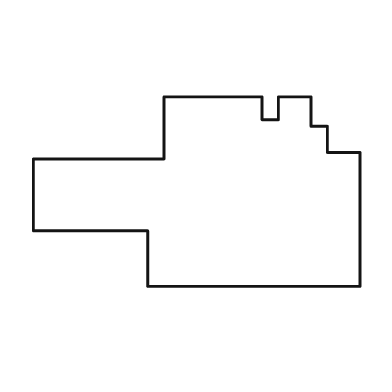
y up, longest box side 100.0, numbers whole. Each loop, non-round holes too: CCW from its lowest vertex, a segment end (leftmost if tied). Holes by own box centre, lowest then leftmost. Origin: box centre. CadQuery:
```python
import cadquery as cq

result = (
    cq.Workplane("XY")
    .moveTo(-15.0, -29.0)
    .lineTo(50.0, -29.0)
    .lineTo(50.0, 12.0)
    .lineTo(40.0, 12.0)
    .lineTo(40.0, 20.0)
    .lineTo(35.0, 20.0)
    .lineTo(35.0, 29.0)
    .lineTo(25.0, 29.0)
    .lineTo(25.0, 22.0)
    .lineTo(20.0, 22.0)
    .lineTo(20.0, 29.0)
    .lineTo(-10.0, 29.0)
    .lineTo(-10.0, 10.0)
    .lineTo(-50.0, 10.0)
    .lineTo(-50.0, -12.0)
    .lineTo(-15.0, -12.0)
    .close()
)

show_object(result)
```